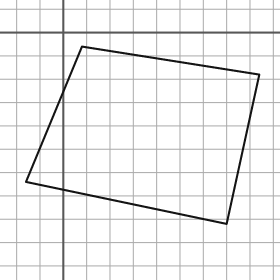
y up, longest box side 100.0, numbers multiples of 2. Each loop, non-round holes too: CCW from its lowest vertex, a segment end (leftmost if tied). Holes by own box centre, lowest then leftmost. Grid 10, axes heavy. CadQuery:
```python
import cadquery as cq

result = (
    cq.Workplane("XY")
    .moveTo(70.0, -82.0)
    .lineTo(84.0, -18.0)
    .lineTo(8.0, -6.0)
    .lineTo(-16.0, -64.0)
    .close()
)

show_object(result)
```